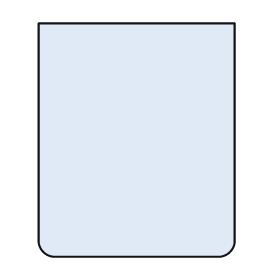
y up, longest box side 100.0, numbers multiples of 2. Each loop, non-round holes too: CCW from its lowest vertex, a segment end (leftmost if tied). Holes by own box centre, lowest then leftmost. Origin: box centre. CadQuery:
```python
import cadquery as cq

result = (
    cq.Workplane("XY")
    .moveTo(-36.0, -50.0)
    .lineTo(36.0, -50.0)
    .threePointArc((40.0, -48.0), (42.0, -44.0))
    .lineTo(42.0, 50.0)
    .lineTo(-42.0, 50.0)
    .lineTo(-42.0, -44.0)
    .threePointArc((-40.0, -48.0), (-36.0, -50.0))
    .close()
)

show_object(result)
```